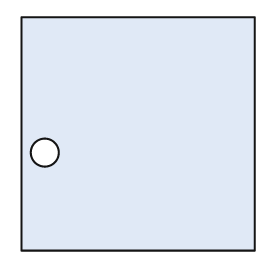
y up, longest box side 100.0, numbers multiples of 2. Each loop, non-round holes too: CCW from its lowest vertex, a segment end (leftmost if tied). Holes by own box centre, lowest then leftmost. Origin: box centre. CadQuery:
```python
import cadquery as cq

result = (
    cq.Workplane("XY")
    .moveTo(-50.0, -50.0)
    .lineTo(50.0, -50.0)
    .lineTo(50.0, 50.0)
    .lineTo(-50.0, 50.0)
    .close()
    .moveTo(-40.0, -8.0)
    .circle(6.0)
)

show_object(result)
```